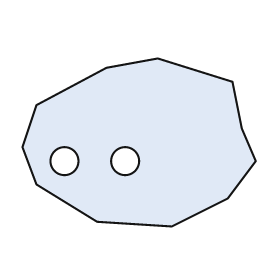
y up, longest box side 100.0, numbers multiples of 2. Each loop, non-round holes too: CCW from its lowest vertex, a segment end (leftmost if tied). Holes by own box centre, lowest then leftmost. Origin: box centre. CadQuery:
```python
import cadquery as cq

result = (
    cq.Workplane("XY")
    .moveTo(14.0, -36.0)
    .lineTo(38.0, -24.0)
    .lineTo(50.0, -8.0)
    .lineTo(44.0, 6.0)
    .lineTo(40.0, 26.0)
    .lineTo(8.0, 36.0)
    .lineTo(-14.0, 32.0)
    .lineTo(-44.0, 16.0)
    .lineTo(-50.0, -2.0)
    .lineTo(-44.0, -18.0)
    .lineTo(-18.0, -34.0)
    .close()
    .moveTo(-32.0, -8.0)
    .circle(6.0)
    .moveTo(-6.0, -8.0)
    .circle(6.0)
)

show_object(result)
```